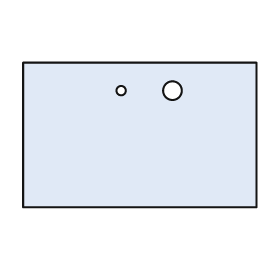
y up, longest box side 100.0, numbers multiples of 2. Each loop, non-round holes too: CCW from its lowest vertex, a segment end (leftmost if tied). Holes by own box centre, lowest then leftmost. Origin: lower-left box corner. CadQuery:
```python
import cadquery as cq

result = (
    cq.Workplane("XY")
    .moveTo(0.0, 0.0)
    .lineTo(100.0, 0.0)
    .lineTo(100.0, 62.0)
    .lineTo(0.0, 62.0)
    .close()
    .moveTo(42.0, 50.0)
    .circle(2.0)
    .moveTo(64.0, 50.0)
    .circle(4.0)
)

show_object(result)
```